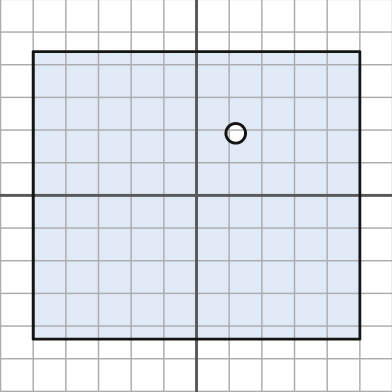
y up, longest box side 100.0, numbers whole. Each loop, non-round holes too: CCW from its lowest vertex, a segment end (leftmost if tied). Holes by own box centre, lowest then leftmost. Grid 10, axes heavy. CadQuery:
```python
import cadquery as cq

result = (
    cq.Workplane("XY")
    .moveTo(-50.0, -44.0)
    .lineTo(50.0, -44.0)
    .lineTo(50.0, 44.0)
    .lineTo(-50.0, 44.0)
    .close()
    .moveTo(12.0, 19.0)
    .circle(3.0)
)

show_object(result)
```